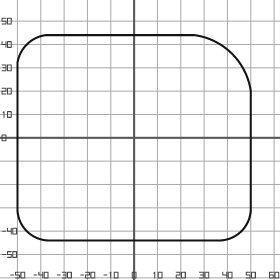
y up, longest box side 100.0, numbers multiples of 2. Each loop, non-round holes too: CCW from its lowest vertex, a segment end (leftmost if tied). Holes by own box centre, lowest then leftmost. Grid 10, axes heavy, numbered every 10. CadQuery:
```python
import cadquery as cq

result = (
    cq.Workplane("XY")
    .moveTo(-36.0, -44.0)
    .lineTo(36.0, -44.0)
    .threePointArc((46.0, -40.0), (50.0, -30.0))
    .lineTo(50.0, 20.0)
    .threePointArc((42.0, 36.0), (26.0, 44.0))
    .lineTo(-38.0, 44.0)
    .threePointArc((-46.0, 40.0), (-50.0, 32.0))
    .lineTo(-50.0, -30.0)
    .threePointArc((-46.0, -40.0), (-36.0, -44.0))
    .close()
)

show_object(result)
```